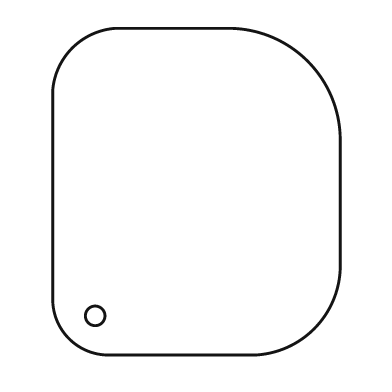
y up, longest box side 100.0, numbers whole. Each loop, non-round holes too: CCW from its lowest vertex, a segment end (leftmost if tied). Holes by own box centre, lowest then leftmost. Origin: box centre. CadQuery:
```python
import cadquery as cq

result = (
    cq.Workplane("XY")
    .moveTo(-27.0, -50.0)
    .lineTo(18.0, -50.0)
    .threePointArc((36.0, -42.0), (44.0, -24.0))
    .lineTo(44.0, 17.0)
    .threePointArc((34.0, 40.0), (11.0, 50.0))
    .lineTo(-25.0, 50.0)
    .threePointArc((-38.0, 44.0), (-44.0, 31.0))
    .lineTo(-44.0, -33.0)
    .threePointArc((-39.0, -45.0), (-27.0, -50.0))
    .close()
    .moveTo(-31.0, -38.0)
    .circle(3.0)
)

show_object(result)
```